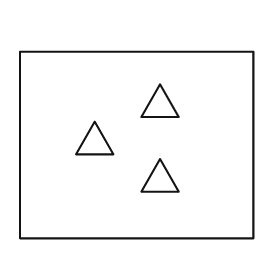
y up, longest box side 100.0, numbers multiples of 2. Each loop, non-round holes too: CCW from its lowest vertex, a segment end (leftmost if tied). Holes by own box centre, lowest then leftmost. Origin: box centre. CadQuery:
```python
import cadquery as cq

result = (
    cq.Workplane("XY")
    .moveTo(-50.0, -40.0)
    .lineTo(50.0, -40.0)
    .lineTo(50.0, 40.0)
    .lineTo(-50.0, 40.0)
    .close()
    .moveTo(2.0, -20.0)
    .lineTo(18.0, -20.0)
    .lineTo(10.0, -6.0)
    .close()
    .moveTo(-26.0, -4.0)
    .lineTo(-10.0, -4.0)
    .lineTo(-18.0, 10.0)
    .close()
    .moveTo(2.0, 12.0)
    .lineTo(18.0, 12.0)
    .lineTo(10.0, 26.0)
    .close()
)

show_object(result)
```